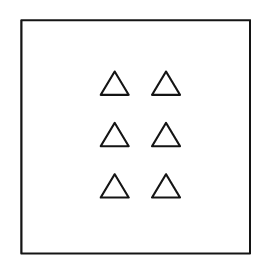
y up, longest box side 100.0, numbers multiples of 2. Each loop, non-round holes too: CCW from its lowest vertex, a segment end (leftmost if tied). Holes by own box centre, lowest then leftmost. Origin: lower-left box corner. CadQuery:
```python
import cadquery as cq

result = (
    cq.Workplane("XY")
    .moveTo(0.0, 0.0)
    .lineTo(98.0, 0.0)
    .lineTo(98.0, 100.0)
    .lineTo(0.0, 100.0)
    .close()
    .moveTo(34.0, 24.0)
    .lineTo(46.0, 24.0)
    .lineTo(40.0, 34.0)
    .close()
    .moveTo(56.0, 24.0)
    .lineTo(68.0, 24.0)
    .lineTo(62.0, 34.0)
    .close()
    .moveTo(34.0, 46.0)
    .lineTo(46.0, 46.0)
    .lineTo(40.0, 56.0)
    .close()
    .moveTo(56.0, 46.0)
    .lineTo(68.0, 46.0)
    .lineTo(62.0, 56.0)
    .close()
    .moveTo(34.0, 68.0)
    .lineTo(46.0, 68.0)
    .lineTo(40.0, 78.0)
    .close()
    .moveTo(56.0, 68.0)
    .lineTo(68.0, 68.0)
    .lineTo(62.0, 78.0)
    .close()
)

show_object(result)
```